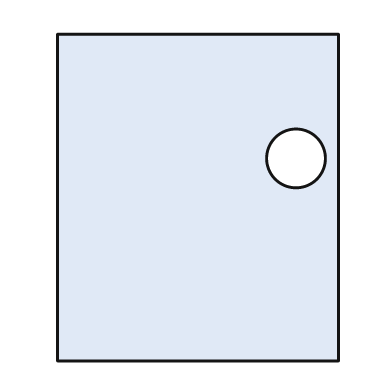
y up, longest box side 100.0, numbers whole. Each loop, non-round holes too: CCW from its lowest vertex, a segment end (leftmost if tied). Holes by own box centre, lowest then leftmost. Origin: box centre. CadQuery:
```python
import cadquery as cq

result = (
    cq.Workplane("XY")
    .moveTo(-43.0, -50.0)
    .lineTo(43.0, -50.0)
    .lineTo(43.0, 50.0)
    .lineTo(-43.0, 50.0)
    .close()
    .moveTo(30.0, 12.0)
    .circle(9.0)
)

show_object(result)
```